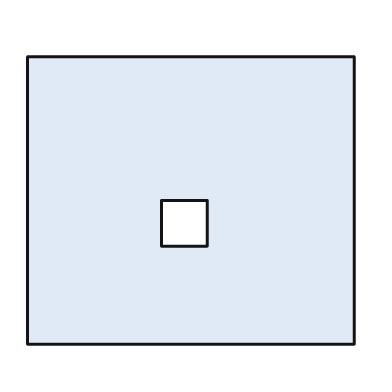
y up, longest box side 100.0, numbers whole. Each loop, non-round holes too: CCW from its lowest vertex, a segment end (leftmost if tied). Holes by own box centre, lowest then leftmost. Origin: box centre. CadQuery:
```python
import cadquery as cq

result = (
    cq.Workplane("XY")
    .moveTo(-50.0, -44.0)
    .lineTo(50.0, -44.0)
    .lineTo(50.0, 44.0)
    .lineTo(-50.0, 44.0)
    .close()
    .moveTo(-9.0, -14.0)
    .lineTo(5.0, -14.0)
    .lineTo(5.0, 0.0)
    .lineTo(-9.0, 0.0)
    .close()
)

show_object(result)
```